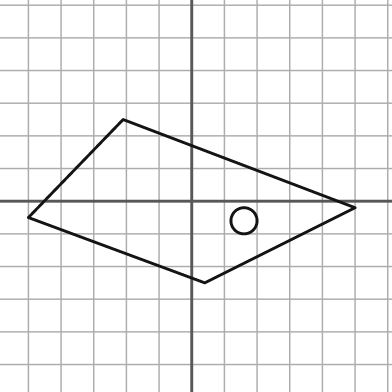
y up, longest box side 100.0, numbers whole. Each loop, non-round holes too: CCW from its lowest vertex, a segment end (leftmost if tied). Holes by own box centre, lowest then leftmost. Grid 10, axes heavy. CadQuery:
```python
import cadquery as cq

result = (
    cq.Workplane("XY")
    .moveTo(4.0, -25.0)
    .lineTo(50.0, -2.0)
    .lineTo(-21.0, 25.0)
    .lineTo(-50.0, -5.0)
    .close()
    .moveTo(16.0, -6.0)
    .circle(4.0)
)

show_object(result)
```